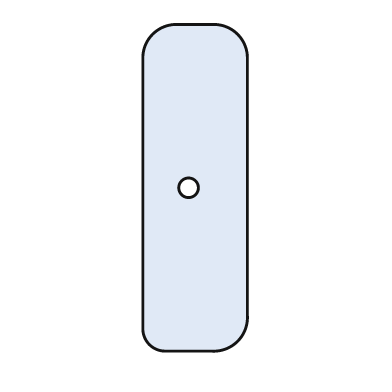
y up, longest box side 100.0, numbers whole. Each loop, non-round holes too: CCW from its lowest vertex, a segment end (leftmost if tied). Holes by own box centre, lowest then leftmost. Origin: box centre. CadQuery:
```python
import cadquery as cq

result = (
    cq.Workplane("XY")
    .moveTo(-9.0, -50.0)
    .lineTo(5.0, -50.0)
    .threePointArc((13.0, -47.0), (16.0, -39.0))
    .lineTo(16.0, 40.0)
    .threePointArc((13.0, 47.0), (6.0, 50.0))
    .lineTo(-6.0, 50.0)
    .threePointArc((-13.0, 47.0), (-16.0, 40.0))
    .lineTo(-16.0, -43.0)
    .threePointArc((-14.0, -48.0), (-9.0, -50.0))
    .close()
    .moveTo(-2.0, 0.0)
    .circle(3.0)
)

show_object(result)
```